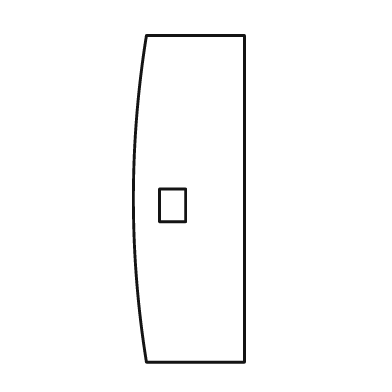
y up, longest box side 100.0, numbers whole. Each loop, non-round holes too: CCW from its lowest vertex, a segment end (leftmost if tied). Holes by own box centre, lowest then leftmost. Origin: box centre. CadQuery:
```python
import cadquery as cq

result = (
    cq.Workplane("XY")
    .moveTo(-13.0, -50.0)
    .lineTo(17.0, -50.0)
    .lineTo(17.0, 50.0)
    .lineTo(-13.0, 50.0)
    .threePointArc((-17.0, 0.0), (-13.0, -50.0))
    .close()
    .moveTo(-9.0, -7.0)
    .lineTo(-1.0, -7.0)
    .lineTo(-1.0, 3.0)
    .lineTo(-9.0, 3.0)
    .close()
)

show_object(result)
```